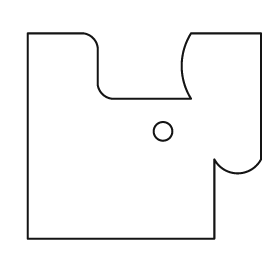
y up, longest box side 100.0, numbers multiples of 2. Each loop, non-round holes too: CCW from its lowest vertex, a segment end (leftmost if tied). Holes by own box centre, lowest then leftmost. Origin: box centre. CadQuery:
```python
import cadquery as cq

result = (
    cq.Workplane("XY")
    .moveTo(-50.0, -44.0)
    .lineTo(30.0, -44.0)
    .lineTo(30.0, -10.0)
    .threePointArc((40.0, -16.0), (50.0, -10.0))
    .lineTo(50.0, 44.0)
    .lineTo(20.0, 44.0)
    .threePointArc((16.0, 30.0), (20.0, 16.0))
    .lineTo(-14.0, 16.0)
    .threePointArc((-18.0, 18.0), (-20.0, 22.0))
    .lineTo(-20.0, 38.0)
    .threePointArc((-22.0, 42.0), (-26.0, 44.0))
    .lineTo(-50.0, 44.0)
    .close()
    .moveTo(8.0, 2.0)
    .circle(4.0)
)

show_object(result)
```